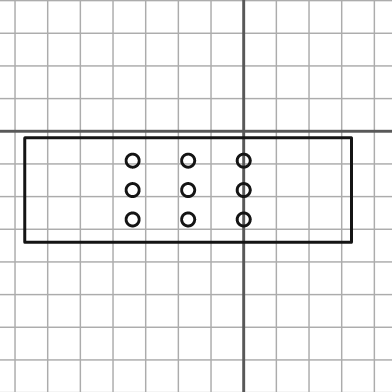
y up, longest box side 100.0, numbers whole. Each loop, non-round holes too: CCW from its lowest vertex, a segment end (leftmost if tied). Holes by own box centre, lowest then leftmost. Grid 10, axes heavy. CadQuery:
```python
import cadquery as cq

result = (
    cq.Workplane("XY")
    .moveTo(-67.0, -34.0)
    .lineTo(33.0, -34.0)
    .lineTo(33.0, -2.0)
    .lineTo(-67.0, -2.0)
    .close()
    .moveTo(-34.0, -27.0)
    .circle(2.0)
    .moveTo(-17.0, -27.0)
    .circle(2.0)
    .moveTo(0.0, -27.0)
    .circle(2.0)
    .moveTo(-34.0, -18.0)
    .circle(2.0)
    .moveTo(-17.0, -18.0)
    .circle(2.0)
    .moveTo(0.0, -18.0)
    .circle(2.0)
    .moveTo(-34.0, -9.0)
    .circle(2.0)
    .moveTo(-17.0, -9.0)
    .circle(2.0)
    .moveTo(0.0, -9.0)
    .circle(2.0)
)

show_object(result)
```